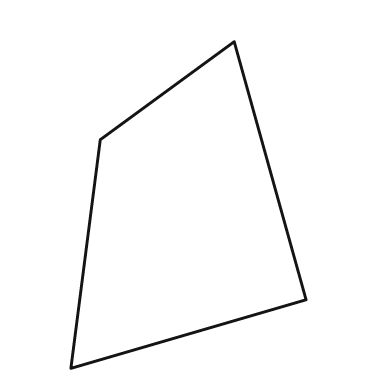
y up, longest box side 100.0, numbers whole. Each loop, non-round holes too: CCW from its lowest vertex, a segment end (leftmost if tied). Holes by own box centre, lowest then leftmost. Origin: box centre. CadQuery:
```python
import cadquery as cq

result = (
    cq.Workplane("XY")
    .moveTo(-36.0, -50.0)
    .lineTo(36.0, -29.0)
    .lineTo(14.0, 50.0)
    .lineTo(-27.0, 20.0)
    .close()
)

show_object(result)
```